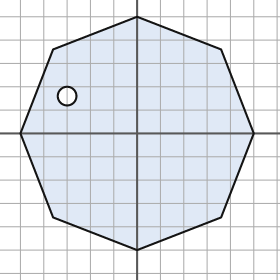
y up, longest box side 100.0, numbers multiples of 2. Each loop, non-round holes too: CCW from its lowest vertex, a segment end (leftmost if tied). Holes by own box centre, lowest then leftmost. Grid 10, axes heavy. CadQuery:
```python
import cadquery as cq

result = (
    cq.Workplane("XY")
    .moveTo(0.0, -50.0)
    .lineTo(36.0, -36.0)
    .lineTo(50.0, 0.0)
    .lineTo(36.0, 36.0)
    .lineTo(0.0, 50.0)
    .lineTo(-36.0, 36.0)
    .lineTo(-50.0, 0.0)
    .lineTo(-36.0, -36.0)
    .close()
    .moveTo(-30.0, 16.0)
    .circle(4.0)
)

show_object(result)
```